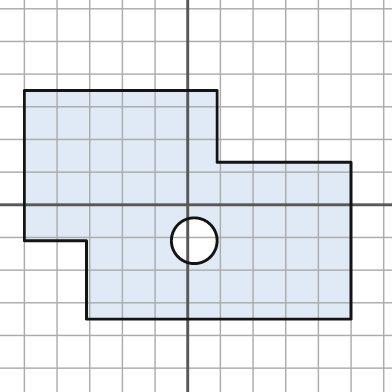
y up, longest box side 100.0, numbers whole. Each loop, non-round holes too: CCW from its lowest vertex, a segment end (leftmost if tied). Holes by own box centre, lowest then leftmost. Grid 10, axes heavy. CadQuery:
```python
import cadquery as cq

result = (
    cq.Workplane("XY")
    .moveTo(-31.0, -35.0)
    .lineTo(50.0, -35.0)
    .lineTo(50.0, 13.0)
    .lineTo(9.0, 13.0)
    .lineTo(9.0, 35.0)
    .lineTo(-50.0, 35.0)
    .lineTo(-50.0, -11.0)
    .lineTo(-31.0, -11.0)
    .close()
    .moveTo(2.0, -11.0)
    .circle(7.0)
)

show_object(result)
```